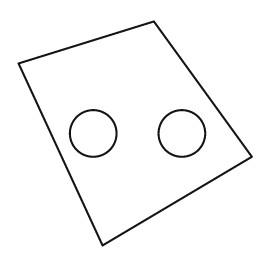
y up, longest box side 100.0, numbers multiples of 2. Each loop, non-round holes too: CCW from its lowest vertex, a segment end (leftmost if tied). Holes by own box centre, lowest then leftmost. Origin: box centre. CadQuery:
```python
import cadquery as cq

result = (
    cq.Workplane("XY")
    .moveTo(-14.0, -48.0)
    .lineTo(50.0, -10.0)
    .lineTo(8.0, 48.0)
    .lineTo(-50.0, 30.0)
    .close()
    .moveTo(-18.0, 0.0)
    .circle(10.0)
    .moveTo(20.0, 0.0)
    .circle(10.0)
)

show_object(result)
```